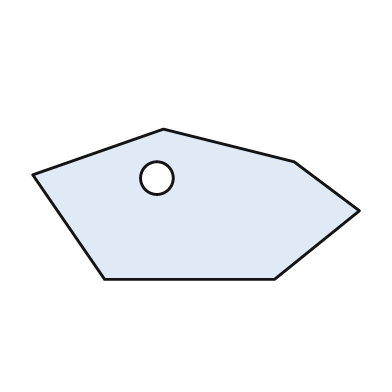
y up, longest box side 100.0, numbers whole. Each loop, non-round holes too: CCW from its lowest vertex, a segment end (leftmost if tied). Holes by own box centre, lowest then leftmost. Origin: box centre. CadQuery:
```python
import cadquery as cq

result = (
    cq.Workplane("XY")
    .moveTo(-28.0, -23.0)
    .lineTo(24.0, -23.0)
    .lineTo(50.0, -2.0)
    .lineTo(30.0, 13.0)
    .lineTo(-10.0, 23.0)
    .lineTo(-50.0, 9.0)
    .close()
    .moveTo(-12.0, 8.0)
    .circle(5.0)
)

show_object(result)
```